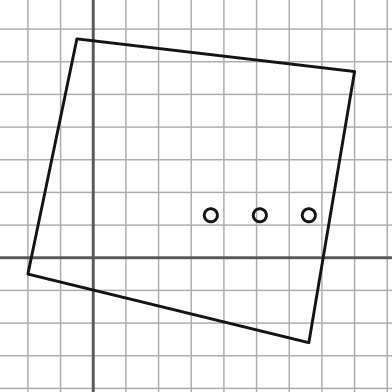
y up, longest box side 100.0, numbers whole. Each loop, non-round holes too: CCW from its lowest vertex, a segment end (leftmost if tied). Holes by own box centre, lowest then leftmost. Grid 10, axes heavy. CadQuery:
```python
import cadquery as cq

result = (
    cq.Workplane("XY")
    .moveTo(66.0, -26.0)
    .lineTo(80.0, 57.0)
    .lineTo(-5.0, 67.0)
    .lineTo(-20.0, -5.0)
    .close()
    .moveTo(36.0, 13.0)
    .circle(2.0)
    .moveTo(51.0, 13.0)
    .circle(2.0)
    .moveTo(66.0, 13.0)
    .circle(2.0)
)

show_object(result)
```